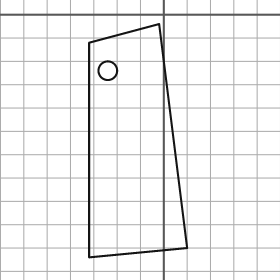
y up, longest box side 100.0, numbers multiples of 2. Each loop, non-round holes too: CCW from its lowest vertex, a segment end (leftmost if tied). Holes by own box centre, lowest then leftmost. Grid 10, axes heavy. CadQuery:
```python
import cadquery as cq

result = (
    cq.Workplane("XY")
    .moveTo(-32.0, -104.0)
    .lineTo(10.0, -100.0)
    .lineTo(-2.0, -4.0)
    .lineTo(-32.0, -12.0)
    .close()
    .moveTo(-24.0, -24.0)
    .circle(4.0)
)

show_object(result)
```